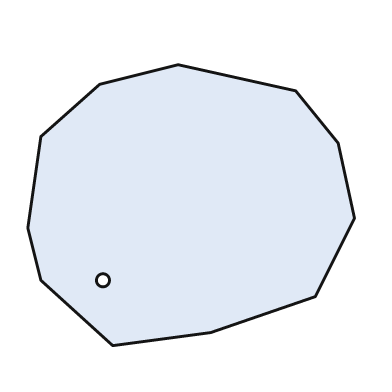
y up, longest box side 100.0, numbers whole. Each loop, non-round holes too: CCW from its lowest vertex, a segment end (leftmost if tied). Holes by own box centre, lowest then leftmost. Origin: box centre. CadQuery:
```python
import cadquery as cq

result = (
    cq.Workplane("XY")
    .moveTo(-24.0, -43.0)
    .lineTo(6.0, -39.0)
    .lineTo(38.0, -28.0)
    .lineTo(50.0, -4.0)
    .lineTo(45.0, 19.0)
    .lineTo(32.0, 35.0)
    .lineTo(-4.0, 43.0)
    .lineTo(-28.0, 37.0)
    .lineTo(-46.0, 21.0)
    .lineTo(-50.0, -7.0)
    .lineTo(-46.0, -23.0)
    .close()
    .moveTo(-27.0, -23.0)
    .circle(2.0)
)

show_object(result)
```